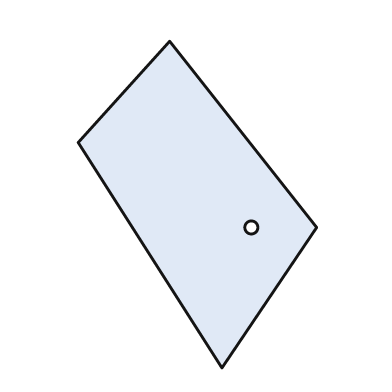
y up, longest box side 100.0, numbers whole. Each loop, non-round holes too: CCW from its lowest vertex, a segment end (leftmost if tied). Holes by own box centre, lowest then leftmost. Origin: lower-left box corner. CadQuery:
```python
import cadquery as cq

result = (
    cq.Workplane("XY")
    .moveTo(44.0, 0.0)
    .lineTo(73.0, 43.0)
    .lineTo(28.0, 100.0)
    .lineTo(0.0, 69.0)
    .close()
    .moveTo(53.0, 43.0)
    .circle(2.0)
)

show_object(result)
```